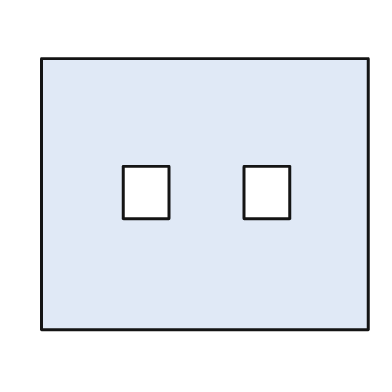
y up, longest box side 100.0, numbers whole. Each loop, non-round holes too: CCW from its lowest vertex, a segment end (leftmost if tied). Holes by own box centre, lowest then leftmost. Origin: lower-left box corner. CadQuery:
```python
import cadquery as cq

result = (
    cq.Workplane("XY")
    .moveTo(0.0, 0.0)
    .lineTo(100.0, 0.0)
    .lineTo(100.0, 83.0)
    .lineTo(0.0, 83.0)
    .close()
    .moveTo(25.0, 34.0)
    .lineTo(39.0, 34.0)
    .lineTo(39.0, 50.0)
    .lineTo(25.0, 50.0)
    .close()
    .moveTo(62.0, 34.0)
    .lineTo(76.0, 34.0)
    .lineTo(76.0, 50.0)
    .lineTo(62.0, 50.0)
    .close()
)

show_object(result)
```